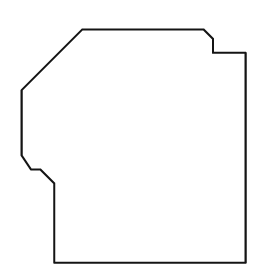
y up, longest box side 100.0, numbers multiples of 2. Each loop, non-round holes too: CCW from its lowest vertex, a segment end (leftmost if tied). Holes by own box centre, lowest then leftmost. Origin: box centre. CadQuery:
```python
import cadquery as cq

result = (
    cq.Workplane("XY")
    .moveTo(-34.0, -50.0)
    .lineTo(48.0, -50.0)
    .lineTo(48.0, 40.0)
    .lineTo(34.0, 40.0)
    .lineTo(34.0, 46.0)
    .lineTo(30.0, 50.0)
    .lineTo(-22.0, 50.0)
    .lineTo(-48.0, 24.0)
    .lineTo(-48.0, -4.0)
    .lineTo(-44.0, -10.0)
    .lineTo(-40.0, -10.0)
    .lineTo(-34.0, -16.0)
    .close()
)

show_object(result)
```